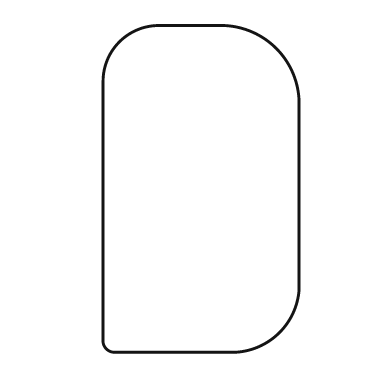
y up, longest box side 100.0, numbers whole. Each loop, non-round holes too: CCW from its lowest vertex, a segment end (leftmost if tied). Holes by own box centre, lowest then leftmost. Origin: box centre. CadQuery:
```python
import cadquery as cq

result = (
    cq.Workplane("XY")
    .moveTo(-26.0, -50.0)
    .lineTo(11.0, -50.0)
    .threePointArc((24.0, -44.0), (30.0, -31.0))
    .lineTo(30.0, 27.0)
    .threePointArc((23.0, 43.0), (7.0, 50.0))
    .lineTo(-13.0, 50.0)
    .threePointArc((-25.0, 45.0), (-30.0, 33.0))
    .lineTo(-30.0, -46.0)
    .threePointArc((-29.0, -49.0), (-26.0, -50.0))
    .close()
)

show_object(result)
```